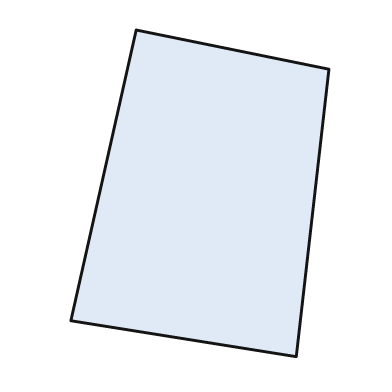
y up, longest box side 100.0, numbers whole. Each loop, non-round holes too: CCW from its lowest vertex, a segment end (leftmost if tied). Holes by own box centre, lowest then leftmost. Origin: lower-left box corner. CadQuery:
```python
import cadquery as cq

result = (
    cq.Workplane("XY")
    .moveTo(69.0, 0.0)
    .lineTo(79.0, 88.0)
    .lineTo(20.0, 100.0)
    .lineTo(0.0, 11.0)
    .close()
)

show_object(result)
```